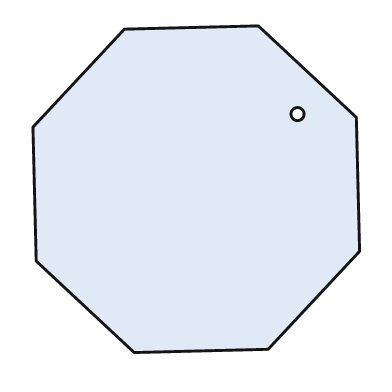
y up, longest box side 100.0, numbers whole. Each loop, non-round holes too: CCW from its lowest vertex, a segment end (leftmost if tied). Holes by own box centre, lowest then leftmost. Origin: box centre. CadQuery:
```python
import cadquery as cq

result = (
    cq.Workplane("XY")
    .moveTo(-19.0, -50.0)
    .lineTo(22.0, -49.0)
    .lineTo(50.0, -19.0)
    .lineTo(49.0, 22.0)
    .lineTo(19.0, 50.0)
    .lineTo(-22.0, 49.0)
    .lineTo(-50.0, 19.0)
    .lineTo(-49.0, -22.0)
    .close()
    .moveTo(31.0, 23.0)
    .circle(2.0)
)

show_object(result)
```